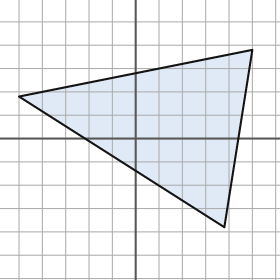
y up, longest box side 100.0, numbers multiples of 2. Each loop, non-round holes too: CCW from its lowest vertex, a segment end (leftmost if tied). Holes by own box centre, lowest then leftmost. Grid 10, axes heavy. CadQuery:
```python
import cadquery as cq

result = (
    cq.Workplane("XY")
    .moveTo(38.0, -38.0)
    .lineTo(50.0, 38.0)
    .lineTo(-50.0, 18.0)
    .close()
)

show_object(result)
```